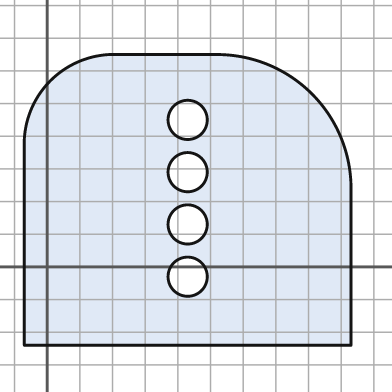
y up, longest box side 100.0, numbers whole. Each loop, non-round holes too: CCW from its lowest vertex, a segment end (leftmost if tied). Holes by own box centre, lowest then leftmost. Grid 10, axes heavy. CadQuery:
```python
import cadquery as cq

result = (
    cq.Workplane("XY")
    .moveTo(-7.0, -24.0)
    .lineTo(93.0, -24.0)
    .lineTo(93.0, 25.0)
    .threePointArc((81.0, 53.0), (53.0, 65.0))
    .lineTo(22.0, 65.0)
    .threePointArc((1.0, 57.0), (-7.0, 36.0))
    .close()
    .moveTo(43.0, -3.0)
    .circle(6.0)
    .moveTo(43.0, 13.0)
    .circle(6.0)
    .moveTo(43.0, 29.0)
    .circle(6.0)
    .moveTo(43.0, 45.0)
    .circle(6.0)
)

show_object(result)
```